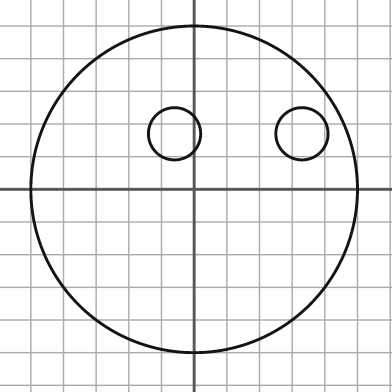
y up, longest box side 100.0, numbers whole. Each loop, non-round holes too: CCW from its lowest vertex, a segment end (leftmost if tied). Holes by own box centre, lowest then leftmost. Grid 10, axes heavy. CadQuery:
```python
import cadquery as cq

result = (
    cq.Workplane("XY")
    .moveTo(0.0, 0.0)
    .circle(50.0)
    .moveTo(-6.0, 17.0)
    .circle(8.0)
    .moveTo(33.0, 17.0)
    .circle(8.0)
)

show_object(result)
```